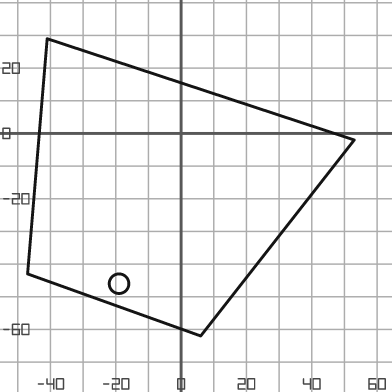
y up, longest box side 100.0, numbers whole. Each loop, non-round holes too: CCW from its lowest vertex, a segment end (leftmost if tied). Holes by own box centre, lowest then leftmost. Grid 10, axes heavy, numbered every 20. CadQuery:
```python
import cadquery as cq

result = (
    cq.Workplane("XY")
    .moveTo(6.0, -62.0)
    .lineTo(53.0, -2.0)
    .lineTo(-41.0, 29.0)
    .lineTo(-47.0, -43.0)
    .close()
    .moveTo(-19.0, -46.0)
    .circle(3.0)
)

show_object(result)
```